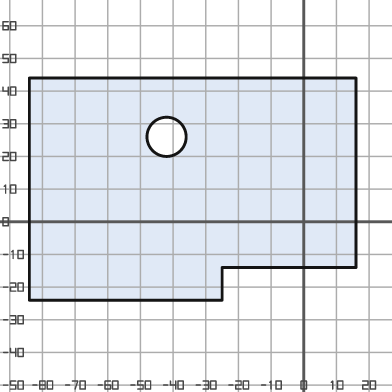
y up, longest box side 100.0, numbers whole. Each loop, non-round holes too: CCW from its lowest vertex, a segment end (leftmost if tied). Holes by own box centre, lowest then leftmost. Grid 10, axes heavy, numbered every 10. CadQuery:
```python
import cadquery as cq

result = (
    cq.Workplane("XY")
    .moveTo(-84.0, -24.0)
    .lineTo(-25.0, -24.0)
    .lineTo(-25.0, -14.0)
    .lineTo(16.0, -14.0)
    .lineTo(16.0, 44.0)
    .lineTo(-84.0, 44.0)
    .close()
    .moveTo(-42.0, 26.0)
    .circle(6.0)
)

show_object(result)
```